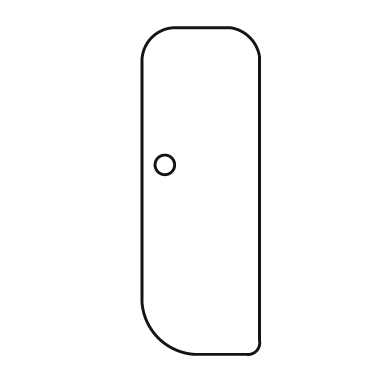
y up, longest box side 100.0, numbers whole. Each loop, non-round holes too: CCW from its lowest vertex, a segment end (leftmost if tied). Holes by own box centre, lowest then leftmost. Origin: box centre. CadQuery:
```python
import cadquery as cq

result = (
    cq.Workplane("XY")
    .moveTo(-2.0, -50.0)
    .lineTo(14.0, -50.0)
    .threePointArc((17.0, -49.0), (18.0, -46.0))
    .lineTo(18.0, 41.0)
    .threePointArc((15.0, 47.0), (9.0, 50.0))
    .lineTo(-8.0, 50.0)
    .threePointArc((-15.0, 47.0), (-18.0, 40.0))
    .lineTo(-18.0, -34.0)
    .threePointArc((-13.0, -45.0), (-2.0, -50.0))
    .close()
    .moveTo(-11.0, 8.0)
    .circle(3.0)
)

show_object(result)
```